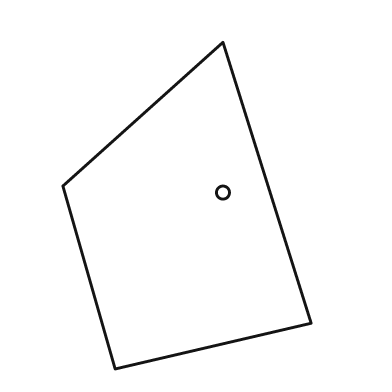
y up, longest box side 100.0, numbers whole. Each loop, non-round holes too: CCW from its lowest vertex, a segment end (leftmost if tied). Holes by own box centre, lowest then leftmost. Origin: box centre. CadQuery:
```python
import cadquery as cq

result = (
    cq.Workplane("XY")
    .moveTo(-22.0, -50.0)
    .lineTo(38.0, -36.0)
    .lineTo(11.0, 50.0)
    .lineTo(-38.0, 6.0)
    .close()
    .moveTo(11.0, 4.0)
    .circle(2.0)
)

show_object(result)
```